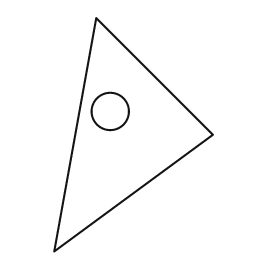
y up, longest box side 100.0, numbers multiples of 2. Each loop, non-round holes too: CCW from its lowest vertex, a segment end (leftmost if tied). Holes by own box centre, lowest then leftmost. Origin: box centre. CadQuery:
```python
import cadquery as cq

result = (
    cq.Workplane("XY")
    .moveTo(-34.0, -50.0)
    .lineTo(34.0, 0.0)
    .lineTo(-16.0, 50.0)
    .close()
    .moveTo(-10.0, 10.0)
    .circle(8.0)
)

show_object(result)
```